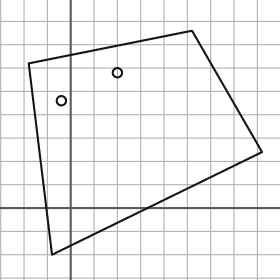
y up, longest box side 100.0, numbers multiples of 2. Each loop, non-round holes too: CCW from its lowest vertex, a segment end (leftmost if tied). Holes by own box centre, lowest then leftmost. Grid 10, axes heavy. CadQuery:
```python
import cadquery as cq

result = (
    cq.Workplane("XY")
    .moveTo(-8.0, -20.0)
    .lineTo(82.0, 24.0)
    .lineTo(52.0, 76.0)
    .lineTo(-18.0, 62.0)
    .close()
    .moveTo(-4.0, 46.0)
    .circle(2.0)
    .moveTo(20.0, 58.0)
    .circle(2.0)
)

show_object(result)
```